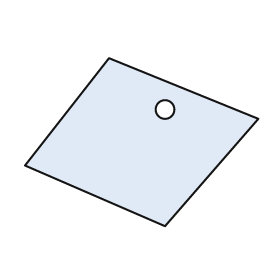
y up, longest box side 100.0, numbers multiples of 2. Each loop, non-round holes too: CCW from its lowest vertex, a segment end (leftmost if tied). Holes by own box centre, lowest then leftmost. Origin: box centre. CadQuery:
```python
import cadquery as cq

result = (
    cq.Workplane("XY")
    .moveTo(10.0, -36.0)
    .lineTo(50.0, 10.0)
    .lineTo(-14.0, 36.0)
    .lineTo(-50.0, -10.0)
    .close()
    .moveTo(10.0, 14.0)
    .circle(4.0)
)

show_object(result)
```